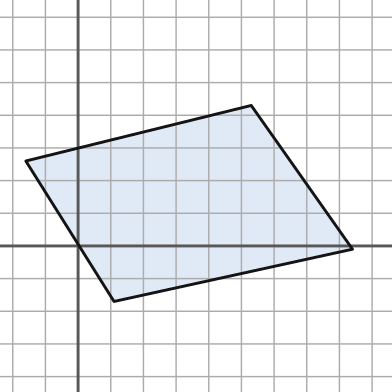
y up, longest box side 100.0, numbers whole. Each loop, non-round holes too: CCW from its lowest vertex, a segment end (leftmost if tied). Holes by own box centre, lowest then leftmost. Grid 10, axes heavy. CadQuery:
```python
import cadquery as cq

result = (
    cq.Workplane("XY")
    .moveTo(11.0, -17.0)
    .lineTo(84.0, -1.0)
    .lineTo(53.0, 43.0)
    .lineTo(-16.0, 26.0)
    .close()
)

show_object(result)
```